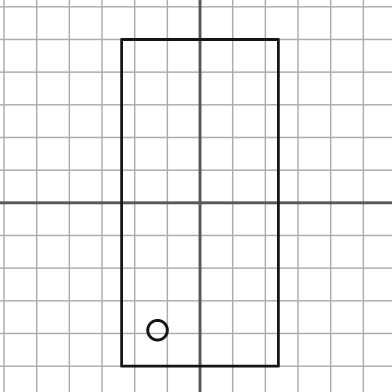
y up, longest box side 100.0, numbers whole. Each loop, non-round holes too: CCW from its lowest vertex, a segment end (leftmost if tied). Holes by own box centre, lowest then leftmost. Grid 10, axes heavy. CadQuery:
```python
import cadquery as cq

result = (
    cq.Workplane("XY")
    .moveTo(-24.0, -50.0)
    .lineTo(24.0, -50.0)
    .lineTo(24.0, 50.0)
    .lineTo(-24.0, 50.0)
    .close()
    .moveTo(-13.0, -39.0)
    .circle(3.0)
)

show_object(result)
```